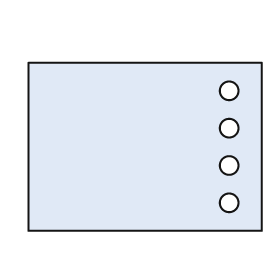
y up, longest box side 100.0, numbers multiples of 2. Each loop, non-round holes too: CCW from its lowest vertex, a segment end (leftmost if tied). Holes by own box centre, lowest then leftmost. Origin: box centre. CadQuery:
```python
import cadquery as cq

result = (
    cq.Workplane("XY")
    .moveTo(-50.0, -36.0)
    .lineTo(50.0, -36.0)
    .lineTo(50.0, 36.0)
    .lineTo(-50.0, 36.0)
    .close()
    .moveTo(36.0, -24.0)
    .circle(4.0)
    .moveTo(36.0, -8.0)
    .circle(4.0)
    .moveTo(36.0, 8.0)
    .circle(4.0)
    .moveTo(36.0, 24.0)
    .circle(4.0)
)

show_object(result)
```